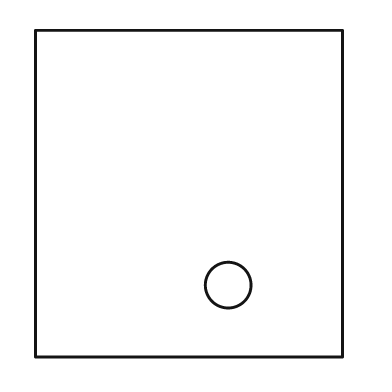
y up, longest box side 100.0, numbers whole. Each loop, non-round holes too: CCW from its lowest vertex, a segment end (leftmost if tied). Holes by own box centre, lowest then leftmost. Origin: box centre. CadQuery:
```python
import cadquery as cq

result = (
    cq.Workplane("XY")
    .moveTo(-47.0, -50.0)
    .lineTo(47.0, -50.0)
    .lineTo(47.0, 50.0)
    .lineTo(-47.0, 50.0)
    .close()
    .moveTo(12.0, -28.0)
    .circle(7.0)
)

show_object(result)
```